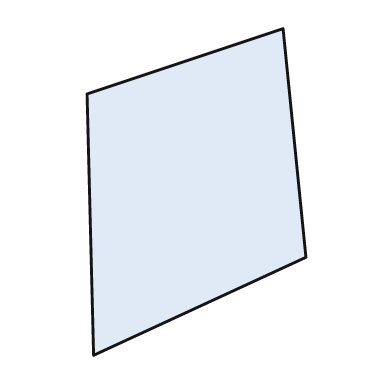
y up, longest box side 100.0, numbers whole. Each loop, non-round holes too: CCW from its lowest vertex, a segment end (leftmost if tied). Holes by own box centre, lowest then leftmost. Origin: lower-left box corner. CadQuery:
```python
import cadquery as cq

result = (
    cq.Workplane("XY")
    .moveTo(2.0, 0.0)
    .lineTo(67.0, 30.0)
    .lineTo(60.0, 100.0)
    .lineTo(0.0, 80.0)
    .close()
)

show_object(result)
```